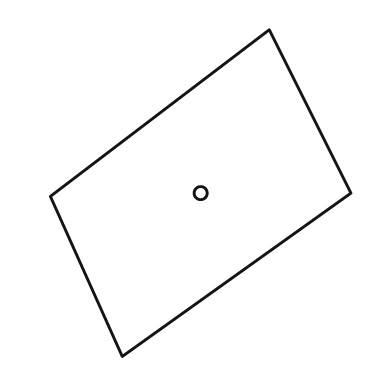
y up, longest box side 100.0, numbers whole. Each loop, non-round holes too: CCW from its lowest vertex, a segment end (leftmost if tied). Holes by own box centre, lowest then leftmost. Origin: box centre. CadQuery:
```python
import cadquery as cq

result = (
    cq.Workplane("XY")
    .moveTo(-24.0, -50.0)
    .lineTo(46.0, 0.0)
    .lineTo(21.0, 50.0)
    .lineTo(-46.0, -1.0)
    .close()
    .moveTo(0.0, 0.0)
    .circle(2.0)
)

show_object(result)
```